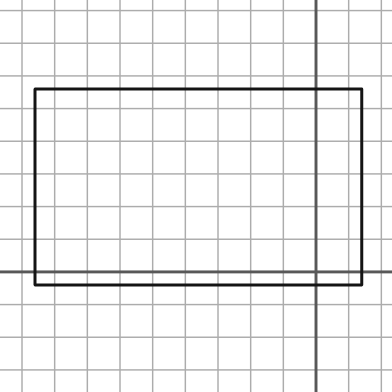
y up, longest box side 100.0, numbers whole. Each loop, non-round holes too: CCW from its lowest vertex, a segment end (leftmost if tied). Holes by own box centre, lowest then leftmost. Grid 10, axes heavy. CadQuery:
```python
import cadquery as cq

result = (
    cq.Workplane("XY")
    .moveTo(-86.0, -4.0)
    .lineTo(14.0, -4.0)
    .lineTo(14.0, 56.0)
    .lineTo(-86.0, 56.0)
    .close()
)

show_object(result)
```